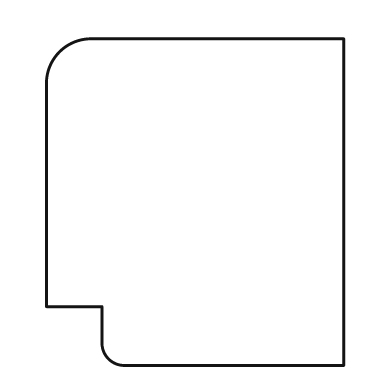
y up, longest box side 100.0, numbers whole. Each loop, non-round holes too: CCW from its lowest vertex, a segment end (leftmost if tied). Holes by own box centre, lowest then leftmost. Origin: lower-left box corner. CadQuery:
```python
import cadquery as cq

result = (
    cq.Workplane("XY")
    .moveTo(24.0, 0.0)
    .lineTo(91.0, 0.0)
    .lineTo(91.0, 100.0)
    .lineTo(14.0, 100.0)
    .threePointArc((4.0, 96.0), (0.0, 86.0))
    .lineTo(0.0, 18.0)
    .lineTo(17.0, 18.0)
    .lineTo(17.0, 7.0)
    .threePointArc((19.0, 2.0), (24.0, 0.0))
    .close()
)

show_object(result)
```